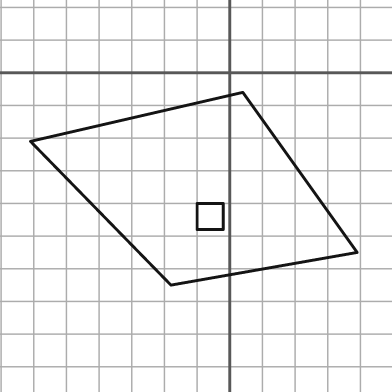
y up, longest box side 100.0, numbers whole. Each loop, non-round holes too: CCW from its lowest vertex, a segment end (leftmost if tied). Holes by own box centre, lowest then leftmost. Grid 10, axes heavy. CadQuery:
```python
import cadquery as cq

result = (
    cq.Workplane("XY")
    .moveTo(-18.0, -65.0)
    .lineTo(39.0, -55.0)
    .lineTo(4.0, -6.0)
    .lineTo(-61.0, -21.0)
    .close()
    .moveTo(-10.0, -48.0)
    .lineTo(-2.0, -48.0)
    .lineTo(-2.0, -40.0)
    .lineTo(-10.0, -40.0)
    .close()
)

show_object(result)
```